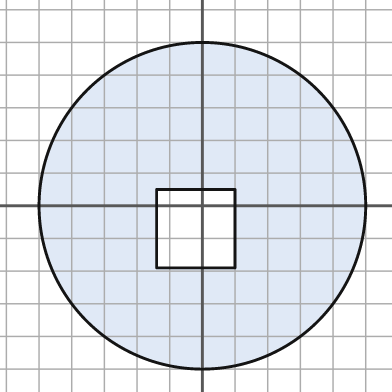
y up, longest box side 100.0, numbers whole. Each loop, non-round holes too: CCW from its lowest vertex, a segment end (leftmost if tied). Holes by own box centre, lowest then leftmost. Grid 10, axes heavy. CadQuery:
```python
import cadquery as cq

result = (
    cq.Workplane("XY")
    .moveTo(0.0, 0.0)
    .circle(50.0)
    .moveTo(-14.0, -19.0)
    .lineTo(10.0, -19.0)
    .lineTo(10.0, 5.0)
    .lineTo(-14.0, 5.0)
    .close()
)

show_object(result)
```